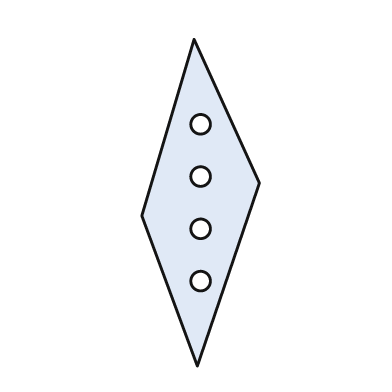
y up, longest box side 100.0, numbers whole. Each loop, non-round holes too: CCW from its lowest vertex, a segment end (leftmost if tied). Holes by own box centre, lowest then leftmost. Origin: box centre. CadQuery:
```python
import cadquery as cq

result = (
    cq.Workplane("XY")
    .moveTo(-1.0, -50.0)
    .lineTo(18.0, 6.0)
    .lineTo(-2.0, 50.0)
    .lineTo(-18.0, -4.0)
    .close()
    .moveTo(0.0, -24.0)
    .circle(3.0)
    .moveTo(0.0, -8.0)
    .circle(3.0)
    .moveTo(0.0, 8.0)
    .circle(3.0)
    .moveTo(0.0, 24.0)
    .circle(3.0)
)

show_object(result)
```